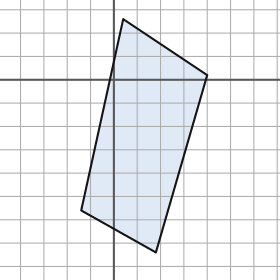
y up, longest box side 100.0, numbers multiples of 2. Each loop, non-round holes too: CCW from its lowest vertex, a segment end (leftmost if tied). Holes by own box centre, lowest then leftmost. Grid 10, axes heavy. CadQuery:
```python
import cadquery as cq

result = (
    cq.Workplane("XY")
    .moveTo(18.0, -74.0)
    .lineTo(40.0, 2.0)
    .lineTo(4.0, 26.0)
    .lineTo(-14.0, -56.0)
    .close()
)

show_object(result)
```